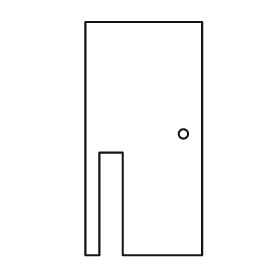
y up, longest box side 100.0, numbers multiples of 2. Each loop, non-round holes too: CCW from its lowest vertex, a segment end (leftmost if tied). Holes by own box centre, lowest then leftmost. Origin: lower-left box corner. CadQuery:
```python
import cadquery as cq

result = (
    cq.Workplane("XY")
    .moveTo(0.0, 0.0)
    .lineTo(6.0, 0.0)
    .lineTo(6.0, 44.0)
    .lineTo(16.0, 44.0)
    .lineTo(16.0, 0.0)
    .lineTo(50.0, 0.0)
    .lineTo(50.0, 100.0)
    .lineTo(0.0, 100.0)
    .close()
    .moveTo(42.0, 52.0)
    .circle(2.0)
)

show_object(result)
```